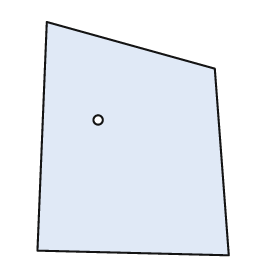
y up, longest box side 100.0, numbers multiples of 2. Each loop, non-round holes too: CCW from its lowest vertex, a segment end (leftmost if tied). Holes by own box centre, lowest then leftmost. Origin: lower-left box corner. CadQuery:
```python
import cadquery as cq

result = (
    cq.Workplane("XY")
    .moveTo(82.0, 0.0)
    .lineTo(76.0, 80.0)
    .lineTo(4.0, 100.0)
    .lineTo(0.0, 2.0)
    .close()
    .moveTo(26.0, 58.0)
    .circle(2.0)
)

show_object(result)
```